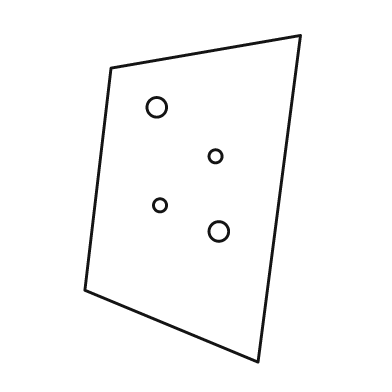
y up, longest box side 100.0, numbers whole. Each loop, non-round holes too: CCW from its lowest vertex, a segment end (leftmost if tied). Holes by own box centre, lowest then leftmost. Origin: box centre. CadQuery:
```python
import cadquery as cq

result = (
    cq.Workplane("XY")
    .moveTo(20.0, -50.0)
    .lineTo(33.0, 50.0)
    .lineTo(-25.0, 40.0)
    .lineTo(-33.0, -28.0)
    .close()
    .moveTo(8.0, -10.0)
    .circle(3.0)
    .moveTo(-10.0, -2.0)
    .circle(2.0)
    .moveTo(7.0, 13.0)
    .circle(2.0)
    .moveTo(-11.0, 28.0)
    .circle(3.0)
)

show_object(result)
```